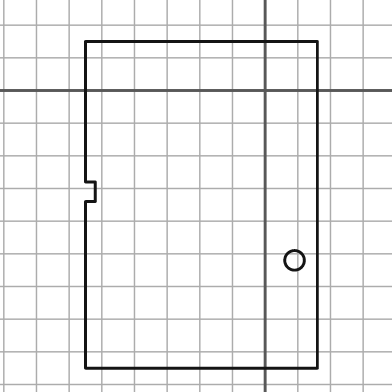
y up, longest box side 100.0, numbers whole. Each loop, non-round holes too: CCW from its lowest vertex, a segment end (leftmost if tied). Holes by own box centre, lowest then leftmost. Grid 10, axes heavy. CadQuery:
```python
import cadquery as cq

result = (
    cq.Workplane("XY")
    .moveTo(-55.0, -85.0)
    .lineTo(16.0, -85.0)
    .lineTo(16.0, 15.0)
    .lineTo(-55.0, 15.0)
    .lineTo(-55.0, -28.0)
    .lineTo(-52.0, -28.0)
    .lineTo(-52.0, -34.0)
    .lineTo(-55.0, -34.0)
    .close()
    .moveTo(9.0, -52.0)
    .circle(3.0)
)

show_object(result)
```